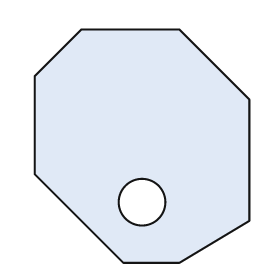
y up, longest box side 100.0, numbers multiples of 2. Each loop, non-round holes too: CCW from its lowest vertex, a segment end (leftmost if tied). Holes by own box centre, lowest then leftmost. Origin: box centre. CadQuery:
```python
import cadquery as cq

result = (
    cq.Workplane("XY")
    .moveTo(-8.0, -50.0)
    .lineTo(16.0, -50.0)
    .lineTo(46.0, -32.0)
    .lineTo(46.0, 20.0)
    .lineTo(16.0, 50.0)
    .lineTo(-26.0, 50.0)
    .lineTo(-46.0, 30.0)
    .lineTo(-46.0, -12.0)
    .close()
    .moveTo(0.0, -24.0)
    .circle(10.0)
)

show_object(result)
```